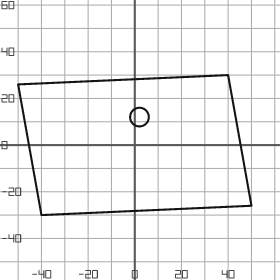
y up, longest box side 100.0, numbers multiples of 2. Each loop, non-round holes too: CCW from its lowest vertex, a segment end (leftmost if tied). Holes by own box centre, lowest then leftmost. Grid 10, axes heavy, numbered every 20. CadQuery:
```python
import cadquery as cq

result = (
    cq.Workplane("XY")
    .moveTo(-40.0, -30.0)
    .lineTo(50.0, -26.0)
    .lineTo(40.0, 30.0)
    .lineTo(-50.0, 26.0)
    .close()
    .moveTo(2.0, 12.0)
    .circle(4.0)
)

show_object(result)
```